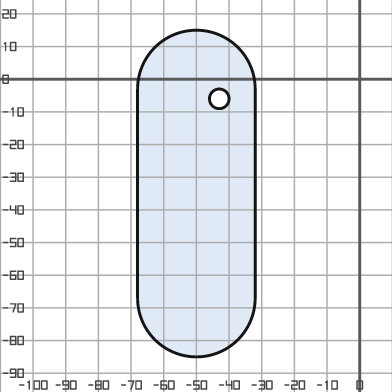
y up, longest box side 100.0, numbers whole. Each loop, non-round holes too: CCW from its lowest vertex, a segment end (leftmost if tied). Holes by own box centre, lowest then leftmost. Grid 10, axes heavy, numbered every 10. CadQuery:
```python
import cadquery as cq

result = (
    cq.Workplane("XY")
    .moveTo(-68.0, -67.0)
    .threePointArc((-50.0, -85.0), (-32.0, -67.0))
    .lineTo(-32.0, -3.0)
    .threePointArc((-50.0, 15.0), (-68.0, -3.0))
    .close()
    .moveTo(-43.0, -6.0)
    .circle(3.0)
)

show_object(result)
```